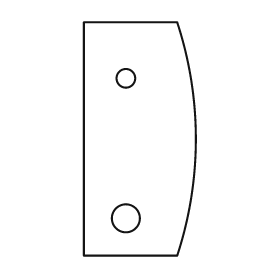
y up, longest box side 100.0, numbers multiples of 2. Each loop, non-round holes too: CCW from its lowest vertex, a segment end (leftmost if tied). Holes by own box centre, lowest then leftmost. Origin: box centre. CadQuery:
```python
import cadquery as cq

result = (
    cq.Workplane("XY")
    .moveTo(-24.0, -50.0)
    .lineTo(16.0, -50.0)
    .threePointArc((24.0, 0.0), (16.0, 50.0))
    .lineTo(-24.0, 50.0)
    .close()
    .moveTo(-6.0, -34.0)
    .circle(6.0)
    .moveTo(-6.0, 26.0)
    .circle(4.0)
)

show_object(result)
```